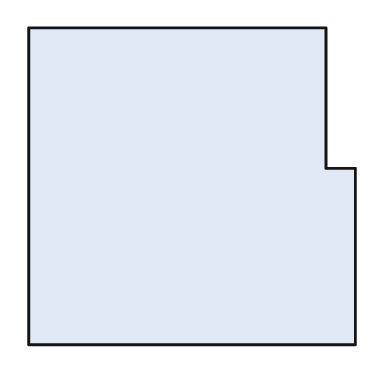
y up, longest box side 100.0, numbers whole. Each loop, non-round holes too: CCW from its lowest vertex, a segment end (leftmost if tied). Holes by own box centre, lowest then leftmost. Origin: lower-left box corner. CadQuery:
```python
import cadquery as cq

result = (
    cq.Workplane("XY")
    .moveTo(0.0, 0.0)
    .lineTo(100.0, 0.0)
    .lineTo(100.0, 54.0)
    .lineTo(91.0, 54.0)
    .lineTo(91.0, 97.0)
    .lineTo(0.0, 97.0)
    .close()
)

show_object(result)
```